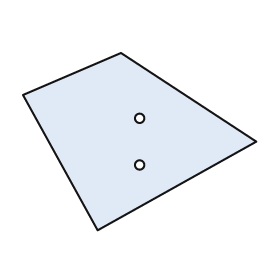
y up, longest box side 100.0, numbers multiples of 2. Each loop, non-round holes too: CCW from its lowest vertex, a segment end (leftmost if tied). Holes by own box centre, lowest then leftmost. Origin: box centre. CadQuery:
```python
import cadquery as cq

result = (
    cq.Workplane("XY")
    .moveTo(-18.0, -38.0)
    .lineTo(50.0, 0.0)
    .lineTo(-8.0, 38.0)
    .lineTo(-50.0, 20.0)
    .close()
    .moveTo(0.0, -10.0)
    .circle(2.0)
    .moveTo(0.0, 10.0)
    .circle(2.0)
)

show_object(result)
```